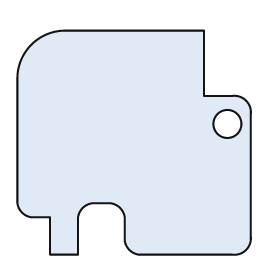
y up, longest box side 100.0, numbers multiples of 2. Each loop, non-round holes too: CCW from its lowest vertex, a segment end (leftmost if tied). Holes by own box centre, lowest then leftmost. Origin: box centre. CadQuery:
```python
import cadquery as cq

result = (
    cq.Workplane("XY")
    .moveTo(-36.0, -48.0)
    .lineTo(-24.0, -48.0)
    .lineTo(-24.0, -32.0)
    .threePointArc((-22.0, -28.0), (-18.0, -26.0))
    .lineTo(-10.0, -26.0)
    .threePointArc((-6.0, -28.0), (-4.0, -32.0))
    .lineTo(-4.0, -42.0)
    .threePointArc((-2.0, -46.0), (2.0, -48.0))
    .lineTo(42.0, -48.0)
    .threePointArc((48.0, -46.0), (50.0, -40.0))
    .lineTo(50.0, 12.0)
    .threePointArc((48.0, 18.0), (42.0, 20.0))
    .lineTo(30.0, 20.0)
    .lineTo(30.0, 48.0)
    .lineTo(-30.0, 48.0)
    .threePointArc((-44.0, 42.0), (-50.0, 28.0))
    .lineTo(-50.0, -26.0)
    .threePointArc((-48.0, -30.0), (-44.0, -32.0))
    .lineTo(-36.0, -32.0)
    .close()
    .moveTo(40.0, 8.0)
    .circle(6.0)
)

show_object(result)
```